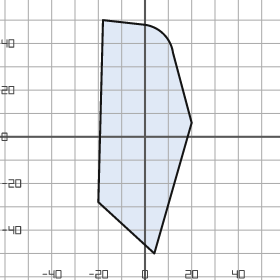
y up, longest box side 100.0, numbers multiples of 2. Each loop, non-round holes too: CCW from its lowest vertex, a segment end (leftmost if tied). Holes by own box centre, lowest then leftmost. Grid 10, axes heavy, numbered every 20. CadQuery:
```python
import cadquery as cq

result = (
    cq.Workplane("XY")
    .moveTo(4.0, -50.0)
    .lineTo(20.0, 6.0)
    .lineTo(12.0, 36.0)
    .threePointArc((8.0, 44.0), (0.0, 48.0))
    .lineTo(-18.0, 50.0)
    .lineTo(-20.0, -28.0)
    .close()
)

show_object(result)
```